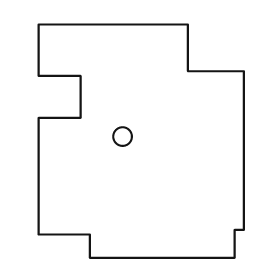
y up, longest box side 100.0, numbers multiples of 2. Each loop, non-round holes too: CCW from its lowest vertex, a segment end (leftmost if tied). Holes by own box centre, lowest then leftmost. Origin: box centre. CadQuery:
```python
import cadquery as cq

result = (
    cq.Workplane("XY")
    .moveTo(-22.0, -50.0)
    .lineTo(40.0, -50.0)
    .lineTo(40.0, -38.0)
    .lineTo(44.0, -38.0)
    .lineTo(44.0, 30.0)
    .lineTo(20.0, 30.0)
    .lineTo(20.0, 50.0)
    .lineTo(-44.0, 50.0)
    .lineTo(-44.0, 28.0)
    .lineTo(-26.0, 28.0)
    .lineTo(-26.0, 10.0)
    .lineTo(-44.0, 10.0)
    .lineTo(-44.0, -40.0)
    .lineTo(-22.0, -40.0)
    .close()
    .moveTo(-8.0, 2.0)
    .circle(4.0)
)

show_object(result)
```